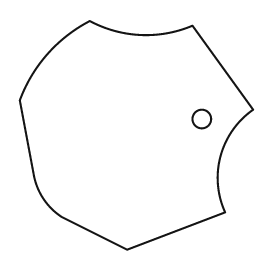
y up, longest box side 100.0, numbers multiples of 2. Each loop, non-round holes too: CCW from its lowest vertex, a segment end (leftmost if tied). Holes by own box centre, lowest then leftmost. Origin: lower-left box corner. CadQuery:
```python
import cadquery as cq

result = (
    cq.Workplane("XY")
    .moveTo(46.0, 0.0)
    .lineTo(88.0, 16.0)
    .threePointArc((86.0, 40.0), (100.0, 60.0))
    .lineTo(74.0, 96.0)
    .threePointArc((52.0, 92.0), (30.0, 98.0))
    .threePointArc((12.0, 84.0), (0.0, 64.0))
    .lineTo(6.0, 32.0)
    .threePointArc((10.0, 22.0), (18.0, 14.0))
    .close()
    .moveTo(78.0, 56.0)
    .circle(4.0)
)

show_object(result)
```